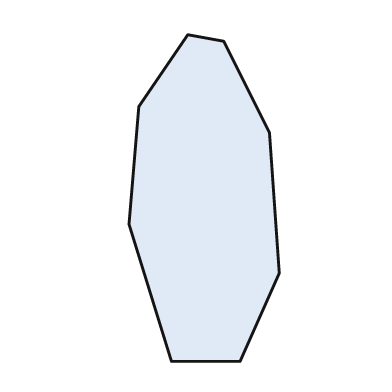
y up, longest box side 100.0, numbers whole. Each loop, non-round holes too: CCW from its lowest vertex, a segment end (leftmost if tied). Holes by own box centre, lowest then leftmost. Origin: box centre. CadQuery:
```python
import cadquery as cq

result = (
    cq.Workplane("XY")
    .moveTo(-10.0, -50.0)
    .lineTo(11.0, -50.0)
    .lineTo(23.0, -23.0)
    .lineTo(20.0, 20.0)
    .lineTo(6.0, 48.0)
    .lineTo(-5.0, 50.0)
    .lineTo(-20.0, 28.0)
    .lineTo(-23.0, -8.0)
    .close()
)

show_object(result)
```